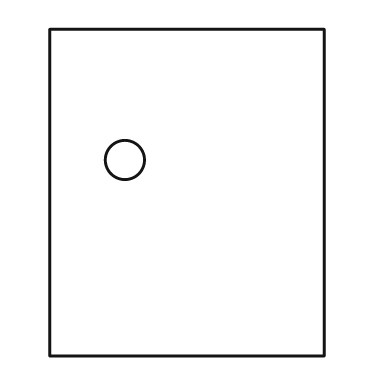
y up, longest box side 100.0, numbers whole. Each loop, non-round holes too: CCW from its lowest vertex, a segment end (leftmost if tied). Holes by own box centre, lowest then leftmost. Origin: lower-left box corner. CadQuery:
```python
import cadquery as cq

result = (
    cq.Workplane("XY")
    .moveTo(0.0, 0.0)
    .lineTo(84.0, 0.0)
    .lineTo(84.0, 100.0)
    .lineTo(0.0, 100.0)
    .close()
    .moveTo(23.0, 60.0)
    .circle(6.0)
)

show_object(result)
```